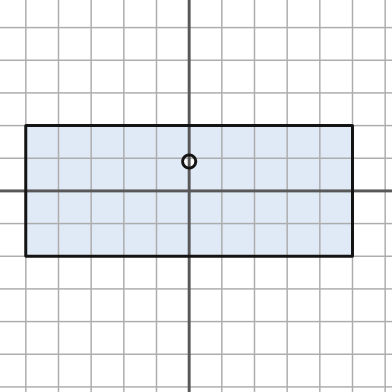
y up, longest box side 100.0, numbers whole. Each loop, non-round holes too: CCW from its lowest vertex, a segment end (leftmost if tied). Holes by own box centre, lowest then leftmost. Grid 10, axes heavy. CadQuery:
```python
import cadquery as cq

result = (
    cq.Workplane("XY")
    .moveTo(-50.0, -20.0)
    .lineTo(50.0, -20.0)
    .lineTo(50.0, 20.0)
    .lineTo(-50.0, 20.0)
    .close()
    .moveTo(0.0, 9.0)
    .circle(2.0)
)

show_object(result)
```